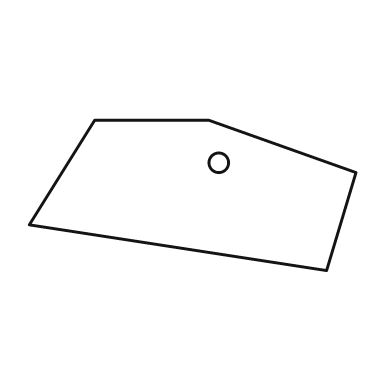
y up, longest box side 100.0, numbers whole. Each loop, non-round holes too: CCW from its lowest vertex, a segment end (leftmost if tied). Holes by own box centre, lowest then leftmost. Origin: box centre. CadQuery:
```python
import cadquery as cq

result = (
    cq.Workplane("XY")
    .moveTo(41.0, -23.0)
    .lineTo(50.0, 7.0)
    .lineTo(5.0, 23.0)
    .lineTo(-30.0, 23.0)
    .lineTo(-50.0, -9.0)
    .close()
    .moveTo(8.0, 10.0)
    .circle(3.0)
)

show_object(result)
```